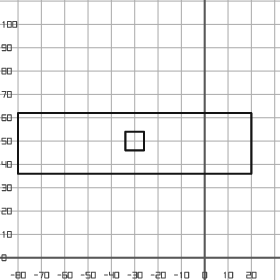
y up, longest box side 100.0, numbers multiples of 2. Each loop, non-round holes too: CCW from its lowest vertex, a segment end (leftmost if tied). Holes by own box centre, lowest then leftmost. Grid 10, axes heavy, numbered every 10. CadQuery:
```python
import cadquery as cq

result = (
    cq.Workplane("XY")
    .moveTo(-80.0, 36.0)
    .lineTo(20.0, 36.0)
    .lineTo(20.0, 62.0)
    .lineTo(-80.0, 62.0)
    .close()
    .moveTo(-34.0, 46.0)
    .lineTo(-26.0, 46.0)
    .lineTo(-26.0, 54.0)
    .lineTo(-34.0, 54.0)
    .close()
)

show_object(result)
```